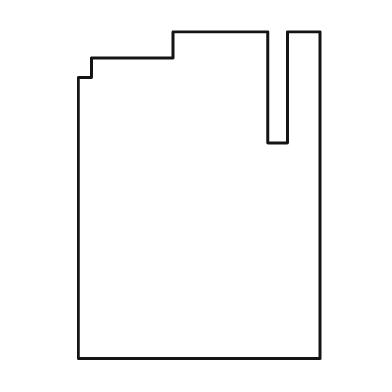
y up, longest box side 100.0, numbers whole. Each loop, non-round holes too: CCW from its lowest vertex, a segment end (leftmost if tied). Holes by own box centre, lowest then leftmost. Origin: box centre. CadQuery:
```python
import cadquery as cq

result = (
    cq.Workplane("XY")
    .moveTo(-37.0, -50.0)
    .lineTo(37.0, -50.0)
    .lineTo(37.0, 50.0)
    .lineTo(27.0, 50.0)
    .lineTo(27.0, 16.0)
    .lineTo(21.0, 16.0)
    .lineTo(21.0, 50.0)
    .lineTo(-8.0, 50.0)
    .lineTo(-8.0, 42.0)
    .lineTo(-33.0, 42.0)
    .lineTo(-33.0, 36.0)
    .lineTo(-37.0, 36.0)
    .close()
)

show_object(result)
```